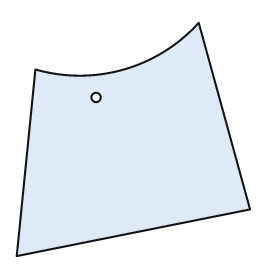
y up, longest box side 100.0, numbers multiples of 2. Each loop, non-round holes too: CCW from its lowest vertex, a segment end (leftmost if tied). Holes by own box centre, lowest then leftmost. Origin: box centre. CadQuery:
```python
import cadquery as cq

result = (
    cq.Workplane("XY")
    .moveTo(-50.0, -50.0)
    .lineTo(50.0, -30.0)
    .lineTo(28.0, 50.0)
    .threePointArc((-4.0, 30.0), (-42.0, 30.0))
    .close()
    .moveTo(-16.0, 18.0)
    .circle(2.0)
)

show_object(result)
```